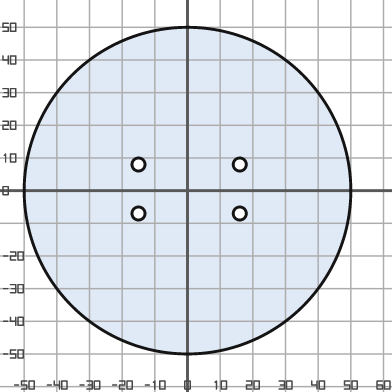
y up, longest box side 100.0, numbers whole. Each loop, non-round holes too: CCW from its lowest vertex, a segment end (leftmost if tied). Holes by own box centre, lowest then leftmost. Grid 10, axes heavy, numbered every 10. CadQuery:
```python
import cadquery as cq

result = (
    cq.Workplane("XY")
    .moveTo(0.0, 0.0)
    .circle(50.0)
    .moveTo(-15.0, -7.0)
    .circle(2.0)
    .moveTo(16.0, -7.0)
    .circle(2.0)
    .moveTo(-15.0, 8.0)
    .circle(2.0)
    .moveTo(16.0, 8.0)
    .circle(2.0)
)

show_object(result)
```